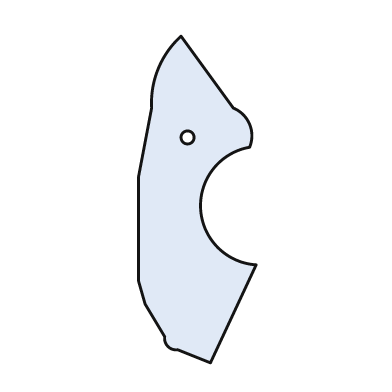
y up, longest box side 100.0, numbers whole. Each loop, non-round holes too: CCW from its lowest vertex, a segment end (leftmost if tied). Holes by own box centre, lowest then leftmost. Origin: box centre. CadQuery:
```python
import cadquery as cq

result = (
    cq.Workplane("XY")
    .moveTo(4.0, -50.0)
    .lineTo(18.0, -20.0)
    .threePointArc((1.0, -3.0), (16.0, 16.0))
    .threePointArc((16.0, 23.0), (11.0, 28.0))
    .lineTo(-5.0, 50.0)
    .threePointArc((-12.0, 40.0), (-14.0, 28.0))
    .lineTo(-18.0, 7.0)
    .lineTo(-18.0, -25.0)
    .lineTo(-16.0, -32.0)
    .lineTo(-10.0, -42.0)
    .threePointArc((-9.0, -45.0), (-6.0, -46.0))
    .close()
    .moveTo(-3.0, 19.0)
    .circle(2.0)
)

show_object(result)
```